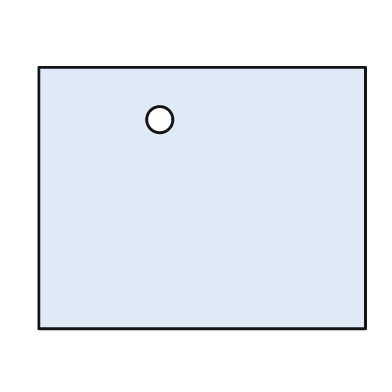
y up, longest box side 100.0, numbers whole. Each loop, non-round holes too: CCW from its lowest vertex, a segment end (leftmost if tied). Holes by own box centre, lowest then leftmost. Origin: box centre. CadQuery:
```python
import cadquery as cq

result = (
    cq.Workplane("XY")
    .moveTo(-50.0, -40.0)
    .lineTo(50.0, -40.0)
    .lineTo(50.0, 40.0)
    .lineTo(-50.0, 40.0)
    .close()
    .moveTo(-13.0, 24.0)
    .circle(4.0)
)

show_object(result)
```